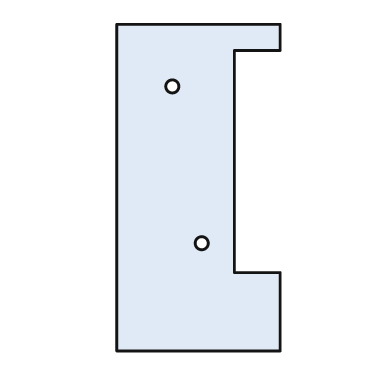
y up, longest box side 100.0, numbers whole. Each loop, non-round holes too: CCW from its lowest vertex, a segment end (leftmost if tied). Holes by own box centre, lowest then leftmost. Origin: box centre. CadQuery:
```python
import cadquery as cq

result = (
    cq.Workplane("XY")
    .moveTo(-25.0, -50.0)
    .lineTo(25.0, -50.0)
    .lineTo(25.0, -26.0)
    .lineTo(11.0, -26.0)
    .lineTo(11.0, 42.0)
    .lineTo(25.0, 42.0)
    .lineTo(25.0, 50.0)
    .lineTo(-25.0, 50.0)
    .close()
    .moveTo(1.0, -17.0)
    .circle(2.0)
    .moveTo(-8.0, 31.0)
    .circle(2.0)
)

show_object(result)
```